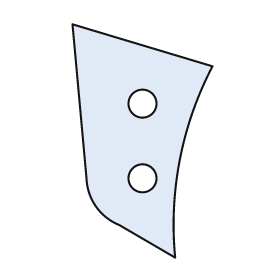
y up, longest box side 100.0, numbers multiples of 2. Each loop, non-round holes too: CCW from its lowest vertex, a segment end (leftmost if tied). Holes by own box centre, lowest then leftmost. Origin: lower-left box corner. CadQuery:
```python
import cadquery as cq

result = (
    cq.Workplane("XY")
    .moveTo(44.0, 0.0)
    .threePointArc((46.0, 42.0), (60.0, 82.0))
    .lineTo(0.0, 100.0)
    .lineTo(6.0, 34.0)
    .threePointArc((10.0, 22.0), (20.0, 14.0))
    .close()
    .moveTo(30.0, 34.0)
    .circle(6.0)
    .moveTo(30.0, 66.0)
    .circle(6.0)
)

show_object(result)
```